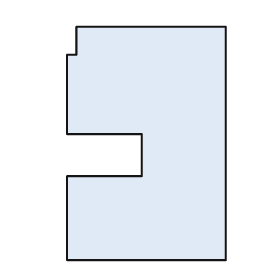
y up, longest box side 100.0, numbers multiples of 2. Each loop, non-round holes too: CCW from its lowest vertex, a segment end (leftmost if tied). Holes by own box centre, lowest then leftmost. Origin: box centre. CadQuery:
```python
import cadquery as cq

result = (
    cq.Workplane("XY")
    .moveTo(-34.0, -50.0)
    .lineTo(34.0, -50.0)
    .lineTo(34.0, 50.0)
    .lineTo(-30.0, 50.0)
    .lineTo(-30.0, 38.0)
    .lineTo(-34.0, 38.0)
    .lineTo(-34.0, 4.0)
    .lineTo(-2.0, 4.0)
    .lineTo(-2.0, -14.0)
    .lineTo(-34.0, -14.0)
    .close()
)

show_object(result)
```